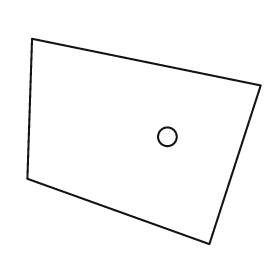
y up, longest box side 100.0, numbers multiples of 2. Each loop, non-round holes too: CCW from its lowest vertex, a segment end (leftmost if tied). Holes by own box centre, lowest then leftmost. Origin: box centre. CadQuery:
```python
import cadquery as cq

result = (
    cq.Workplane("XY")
    .moveTo(28.0, -44.0)
    .lineTo(50.0, 24.0)
    .lineTo(-48.0, 44.0)
    .lineTo(-50.0, -16.0)
    .close()
    .moveTo(10.0, 2.0)
    .circle(4.0)
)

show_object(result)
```